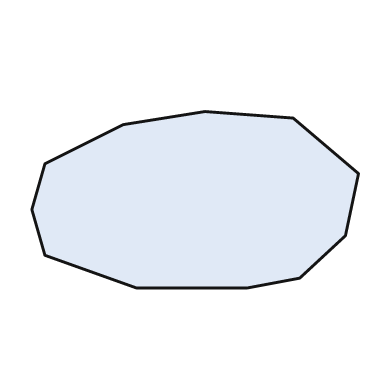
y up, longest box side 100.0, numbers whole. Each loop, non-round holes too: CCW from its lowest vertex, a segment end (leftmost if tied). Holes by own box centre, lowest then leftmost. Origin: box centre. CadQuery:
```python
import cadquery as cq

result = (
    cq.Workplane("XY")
    .moveTo(-18.0, -27.0)
    .lineTo(16.0, -27.0)
    .lineTo(32.0, -24.0)
    .lineTo(46.0, -11.0)
    .lineTo(50.0, 8.0)
    .lineTo(30.0, 25.0)
    .lineTo(3.0, 27.0)
    .lineTo(-22.0, 23.0)
    .lineTo(-46.0, 11.0)
    .lineTo(-50.0, -3.0)
    .lineTo(-46.0, -17.0)
    .close()
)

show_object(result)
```